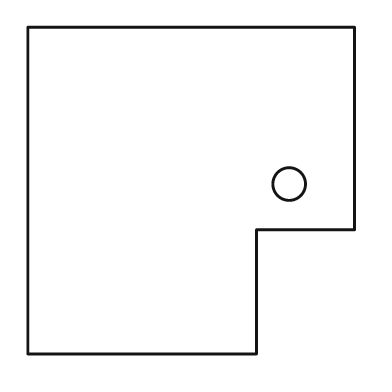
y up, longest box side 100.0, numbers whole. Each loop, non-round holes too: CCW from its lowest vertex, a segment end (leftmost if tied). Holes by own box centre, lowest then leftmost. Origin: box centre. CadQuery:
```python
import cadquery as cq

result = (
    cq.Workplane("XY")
    .moveTo(-50.0, -50.0)
    .lineTo(20.0, -50.0)
    .lineTo(20.0, -12.0)
    .lineTo(50.0, -12.0)
    .lineTo(50.0, 50.0)
    .lineTo(-50.0, 50.0)
    .close()
    .moveTo(30.0, 2.0)
    .circle(5.0)
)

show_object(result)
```